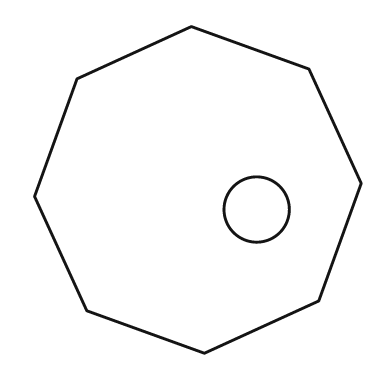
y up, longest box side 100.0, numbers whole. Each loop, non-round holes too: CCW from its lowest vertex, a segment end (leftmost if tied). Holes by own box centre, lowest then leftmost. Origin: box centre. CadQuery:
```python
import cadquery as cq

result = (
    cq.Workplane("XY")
    .moveTo(2.0, -50.0)
    .lineTo(37.0, -34.0)
    .lineTo(50.0, 2.0)
    .lineTo(34.0, 37.0)
    .lineTo(-2.0, 50.0)
    .lineTo(-37.0, 34.0)
    .lineTo(-50.0, -2.0)
    .lineTo(-34.0, -37.0)
    .close()
    .moveTo(18.0, -6.0)
    .circle(10.0)
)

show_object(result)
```